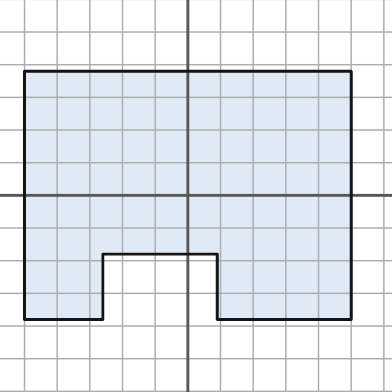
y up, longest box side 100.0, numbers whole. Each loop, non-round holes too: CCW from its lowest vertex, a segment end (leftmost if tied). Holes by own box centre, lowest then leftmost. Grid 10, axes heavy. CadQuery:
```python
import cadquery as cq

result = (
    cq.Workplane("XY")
    .moveTo(-50.0, -38.0)
    .lineTo(-26.0, -38.0)
    .lineTo(-26.0, -18.0)
    .lineTo(9.0, -18.0)
    .lineTo(9.0, -38.0)
    .lineTo(50.0, -38.0)
    .lineTo(50.0, 38.0)
    .lineTo(-50.0, 38.0)
    .close()
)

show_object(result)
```